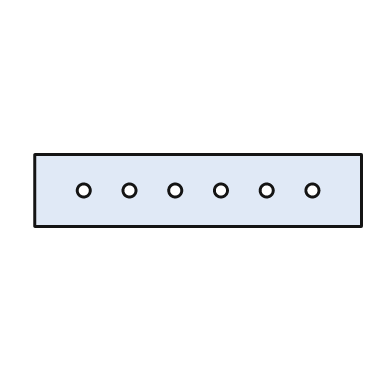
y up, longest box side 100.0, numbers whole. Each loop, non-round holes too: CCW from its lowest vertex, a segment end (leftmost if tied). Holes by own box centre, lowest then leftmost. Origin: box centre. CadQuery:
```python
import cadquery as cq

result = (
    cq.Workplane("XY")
    .moveTo(-50.0, -11.0)
    .lineTo(50.0, -11.0)
    .lineTo(50.0, 11.0)
    .lineTo(-50.0, 11.0)
    .close()
    .moveTo(-35.0, 0.0)
    .circle(2.0)
    .moveTo(-21.0, 0.0)
    .circle(2.0)
    .moveTo(-7.0, 0.0)
    .circle(2.0)
    .moveTo(7.0, 0.0)
    .circle(2.0)
    .moveTo(21.0, 0.0)
    .circle(2.0)
    .moveTo(35.0, 0.0)
    .circle(2.0)
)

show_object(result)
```